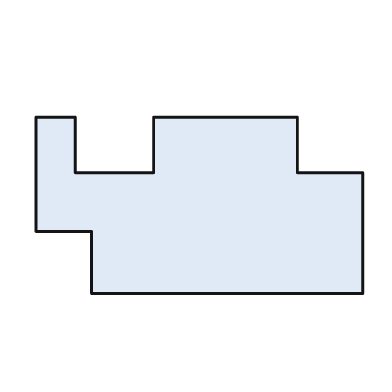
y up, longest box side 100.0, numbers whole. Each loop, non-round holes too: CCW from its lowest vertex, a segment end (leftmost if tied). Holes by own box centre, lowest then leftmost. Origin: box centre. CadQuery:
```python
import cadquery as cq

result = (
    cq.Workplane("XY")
    .moveTo(-33.0, -27.0)
    .lineTo(50.0, -27.0)
    .lineTo(50.0, 10.0)
    .lineTo(30.0, 10.0)
    .lineTo(30.0, 27.0)
    .lineTo(-14.0, 27.0)
    .lineTo(-14.0, 10.0)
    .lineTo(-38.0, 10.0)
    .lineTo(-38.0, 27.0)
    .lineTo(-50.0, 27.0)
    .lineTo(-50.0, -8.0)
    .lineTo(-33.0, -8.0)
    .close()
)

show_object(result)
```